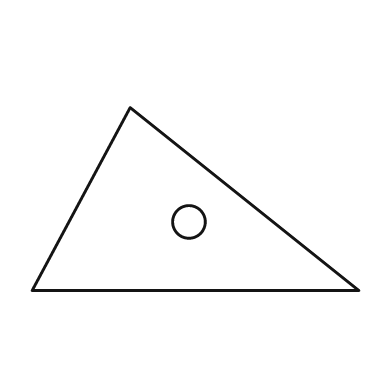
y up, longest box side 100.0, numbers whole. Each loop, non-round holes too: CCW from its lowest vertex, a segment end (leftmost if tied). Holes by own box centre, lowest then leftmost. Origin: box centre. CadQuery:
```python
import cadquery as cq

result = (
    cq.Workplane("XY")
    .moveTo(-50.0, -28.0)
    .lineTo(50.0, -28.0)
    .lineTo(-20.0, 28.0)
    .close()
    .moveTo(-2.0, -7.0)
    .circle(5.0)
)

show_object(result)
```